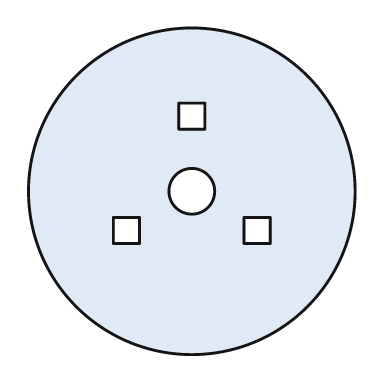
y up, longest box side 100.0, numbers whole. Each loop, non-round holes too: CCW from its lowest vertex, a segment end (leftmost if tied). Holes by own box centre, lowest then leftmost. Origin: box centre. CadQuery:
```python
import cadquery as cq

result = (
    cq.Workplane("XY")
    .moveTo(0.0, 0.0)
    .circle(50.0)
    .moveTo(-24.0, -16.0)
    .lineTo(-16.0, -16.0)
    .lineTo(-16.0, -8.0)
    .lineTo(-24.0, -8.0)
    .close()
    .moveTo(16.0, -16.0)
    .lineTo(24.0, -16.0)
    .lineTo(24.0, -8.0)
    .lineTo(16.0, -8.0)
    .close()
    .moveTo(0.0, 0.0)
    .circle(7.0)
    .moveTo(-4.0, 19.0)
    .lineTo(4.0, 19.0)
    .lineTo(4.0, 27.0)
    .lineTo(-4.0, 27.0)
    .close()
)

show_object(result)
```